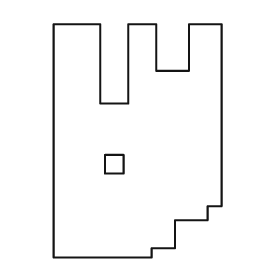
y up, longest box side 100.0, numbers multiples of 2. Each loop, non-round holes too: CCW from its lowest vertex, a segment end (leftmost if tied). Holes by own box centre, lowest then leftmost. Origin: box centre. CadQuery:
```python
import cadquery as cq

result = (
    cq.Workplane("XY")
    .moveTo(-36.0, -50.0)
    .lineTo(6.0, -50.0)
    .lineTo(6.0, -46.0)
    .lineTo(16.0, -46.0)
    .lineTo(16.0, -34.0)
    .lineTo(30.0, -34.0)
    .lineTo(30.0, -28.0)
    .lineTo(36.0, -28.0)
    .lineTo(36.0, 50.0)
    .lineTo(22.0, 50.0)
    .lineTo(22.0, 30.0)
    .lineTo(8.0, 30.0)
    .lineTo(8.0, 50.0)
    .lineTo(-4.0, 50.0)
    .lineTo(-4.0, 16.0)
    .lineTo(-16.0, 16.0)
    .lineTo(-16.0, 50.0)
    .lineTo(-36.0, 50.0)
    .close()
    .moveTo(-14.0, -14.0)
    .lineTo(-6.0, -14.0)
    .lineTo(-6.0, -6.0)
    .lineTo(-14.0, -6.0)
    .close()
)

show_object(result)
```